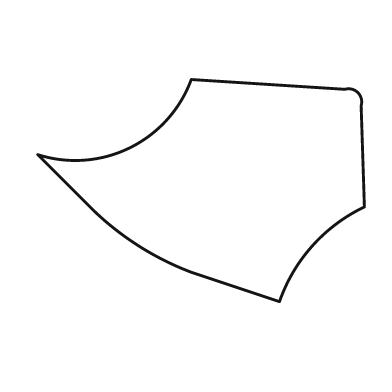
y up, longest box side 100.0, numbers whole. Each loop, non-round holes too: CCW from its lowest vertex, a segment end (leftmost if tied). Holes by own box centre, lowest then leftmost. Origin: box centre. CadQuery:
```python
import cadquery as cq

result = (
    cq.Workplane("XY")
    .moveTo(24.0, -34.0)
    .threePointArc((34.0, -17.0), (50.0, -5.0))
    .lineTo(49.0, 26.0)
    .threePointArc((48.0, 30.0), (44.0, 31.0))
    .lineTo(-3.0, 34.0)
    .threePointArc((-22.0, 13.0), (-50.0, 11.0))
    .lineTo(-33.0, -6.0)
    .threePointArc((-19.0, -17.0), (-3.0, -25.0))
    .close()
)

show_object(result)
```